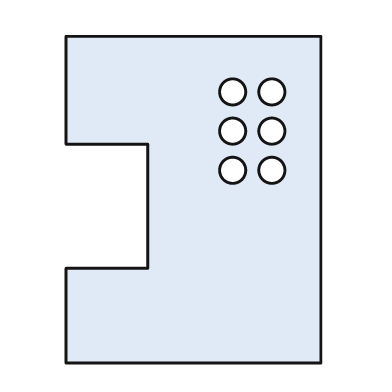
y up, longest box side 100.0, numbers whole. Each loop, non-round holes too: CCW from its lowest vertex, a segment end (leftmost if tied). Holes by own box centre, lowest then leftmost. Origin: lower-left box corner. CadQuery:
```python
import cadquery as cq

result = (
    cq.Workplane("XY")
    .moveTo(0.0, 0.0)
    .lineTo(78.0, 0.0)
    .lineTo(78.0, 100.0)
    .lineTo(0.0, 100.0)
    .lineTo(0.0, 67.0)
    .lineTo(25.0, 67.0)
    .lineTo(25.0, 29.0)
    .lineTo(0.0, 29.0)
    .close()
    .moveTo(51.0, 59.0)
    .circle(4.0)
    .moveTo(63.0, 59.0)
    .circle(4.0)
    .moveTo(51.0, 71.0)
    .circle(4.0)
    .moveTo(63.0, 71.0)
    .circle(4.0)
    .moveTo(51.0, 83.0)
    .circle(4.0)
    .moveTo(63.0, 83.0)
    .circle(4.0)
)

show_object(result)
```